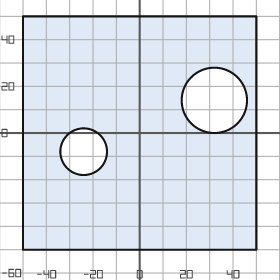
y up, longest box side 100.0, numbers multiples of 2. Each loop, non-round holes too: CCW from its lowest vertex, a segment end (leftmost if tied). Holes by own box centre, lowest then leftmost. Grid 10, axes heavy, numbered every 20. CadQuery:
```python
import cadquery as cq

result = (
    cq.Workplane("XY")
    .moveTo(-50.0, -50.0)
    .lineTo(50.0, -50.0)
    .lineTo(50.0, 50.0)
    .lineTo(-50.0, 50.0)
    .close()
    .moveTo(-24.0, -8.0)
    .circle(10.0)
    .moveTo(32.0, 14.0)
    .circle(14.0)
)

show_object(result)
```